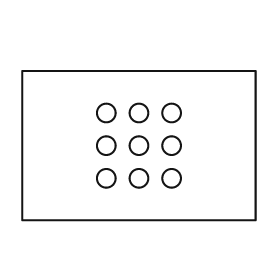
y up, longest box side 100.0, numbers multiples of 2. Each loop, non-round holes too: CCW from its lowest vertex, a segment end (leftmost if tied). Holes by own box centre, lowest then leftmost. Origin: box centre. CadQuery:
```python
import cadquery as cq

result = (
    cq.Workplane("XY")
    .moveTo(-50.0, -32.0)
    .lineTo(50.0, -32.0)
    .lineTo(50.0, 32.0)
    .lineTo(-50.0, 32.0)
    .close()
    .moveTo(-14.0, -14.0)
    .circle(4.0)
    .moveTo(0.0, -14.0)
    .circle(4.0)
    .moveTo(14.0, -14.0)
    .circle(4.0)
    .moveTo(-14.0, 0.0)
    .circle(4.0)
    .moveTo(0.0, 0.0)
    .circle(4.0)
    .moveTo(14.0, 0.0)
    .circle(4.0)
    .moveTo(-14.0, 14.0)
    .circle(4.0)
    .moveTo(0.0, 14.0)
    .circle(4.0)
    .moveTo(14.0, 14.0)
    .circle(4.0)
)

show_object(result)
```